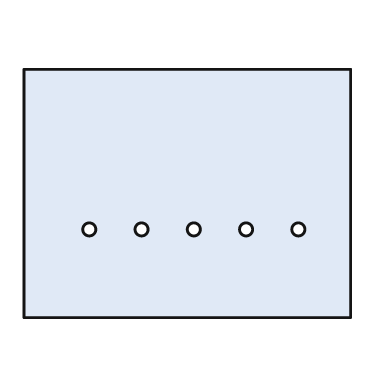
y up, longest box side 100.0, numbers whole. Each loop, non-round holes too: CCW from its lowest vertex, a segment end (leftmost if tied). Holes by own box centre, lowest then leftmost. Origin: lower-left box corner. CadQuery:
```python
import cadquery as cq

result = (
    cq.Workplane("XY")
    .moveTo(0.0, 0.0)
    .lineTo(100.0, 0.0)
    .lineTo(100.0, 76.0)
    .lineTo(0.0, 76.0)
    .close()
    .moveTo(20.0, 27.0)
    .circle(2.0)
    .moveTo(36.0, 27.0)
    .circle(2.0)
    .moveTo(52.0, 27.0)
    .circle(2.0)
    .moveTo(68.0, 27.0)
    .circle(2.0)
    .moveTo(84.0, 27.0)
    .circle(2.0)
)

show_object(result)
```